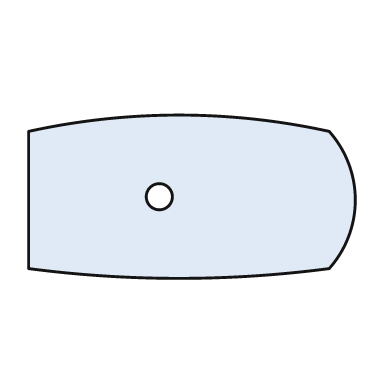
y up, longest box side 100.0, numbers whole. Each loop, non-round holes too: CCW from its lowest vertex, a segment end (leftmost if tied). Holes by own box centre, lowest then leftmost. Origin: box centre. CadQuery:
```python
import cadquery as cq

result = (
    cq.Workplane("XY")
    .moveTo(-50.0, -22.0)
    .threePointArc((-4.0, -25.0), (42.0, -22.0))
    .threePointArc((50.0, -1.0), (42.0, 20.0))
    .threePointArc((-4.0, 25.0), (-50.0, 20.0))
    .close()
    .moveTo(-10.0, 0.0)
    .circle(4.0)
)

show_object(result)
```